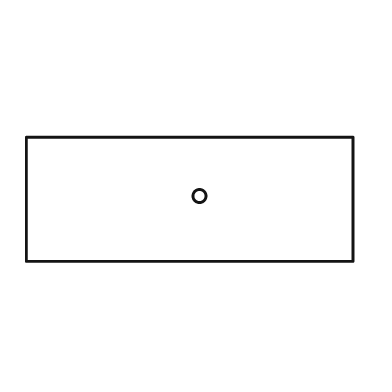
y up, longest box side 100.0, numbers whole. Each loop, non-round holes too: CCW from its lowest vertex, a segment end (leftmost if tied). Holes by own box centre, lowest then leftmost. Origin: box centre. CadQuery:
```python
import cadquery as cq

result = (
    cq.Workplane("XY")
    .moveTo(-50.0, -19.0)
    .lineTo(50.0, -19.0)
    .lineTo(50.0, 19.0)
    .lineTo(-50.0, 19.0)
    .close()
    .moveTo(3.0, 1.0)
    .circle(2.0)
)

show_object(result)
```